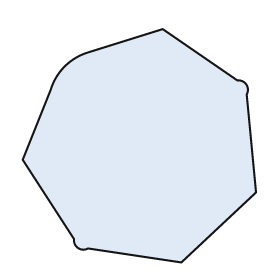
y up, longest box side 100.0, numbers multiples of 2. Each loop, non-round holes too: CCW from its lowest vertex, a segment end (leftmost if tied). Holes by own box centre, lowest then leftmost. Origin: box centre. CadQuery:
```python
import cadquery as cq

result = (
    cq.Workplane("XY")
    .moveTo(18.0, -50.0)
    .lineTo(50.0, -20.0)
    .lineTo(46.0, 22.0)
    .threePointArc((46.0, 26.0), (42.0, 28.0))
    .lineTo(10.0, 50.0)
    .lineTo(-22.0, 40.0)
    .threePointArc((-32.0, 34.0), (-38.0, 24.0))
    .lineTo(-50.0, -6.0)
    .lineTo(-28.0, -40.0)
    .threePointArc((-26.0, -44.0), (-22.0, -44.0))
    .close()
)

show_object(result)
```